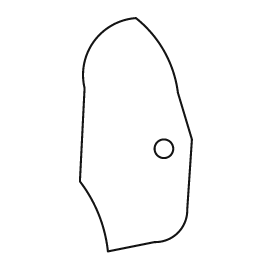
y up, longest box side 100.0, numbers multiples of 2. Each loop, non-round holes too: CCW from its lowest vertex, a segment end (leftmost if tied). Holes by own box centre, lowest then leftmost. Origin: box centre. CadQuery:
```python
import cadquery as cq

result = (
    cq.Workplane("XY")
    .moveTo(-12.0, -50.0)
    .lineTo(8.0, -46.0)
    .threePointArc((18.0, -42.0), (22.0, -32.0))
    .lineTo(24.0, -2.0)
    .lineTo(18.0, 18.0)
    .threePointArc((12.0, 36.0), (0.0, 50.0))
    .threePointArc((-18.0, 40.0), (-22.0, 20.0))
    .lineTo(-24.0, -20.0)
    .threePointArc((-16.0, -34.0), (-12.0, -50.0))
    .close()
    .moveTo(12.0, -6.0)
    .circle(4.0)
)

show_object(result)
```